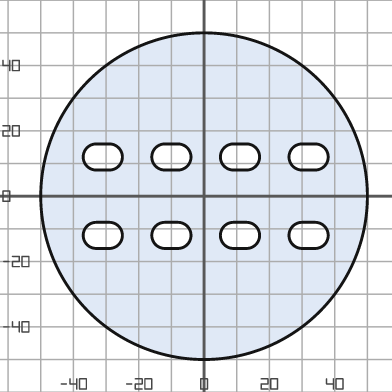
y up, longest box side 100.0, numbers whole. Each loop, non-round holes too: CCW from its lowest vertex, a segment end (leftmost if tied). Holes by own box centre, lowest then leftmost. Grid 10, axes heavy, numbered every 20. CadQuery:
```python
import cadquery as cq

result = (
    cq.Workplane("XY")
    .moveTo(0.0, 0.0)
    .circle(50.0)
    .moveTo(-33.0, -16.0)
    .lineTo(-29.0, -16.0)
    .threePointArc((-25.0, -12.0), (-29.0, -8.0))
    .lineTo(-33.0, -8.0)
    .threePointArc((-37.0, -12.0), (-33.0, -16.0))
    .close()
    .moveTo(-12.0, -16.0)
    .lineTo(-8.0, -16.0)
    .threePointArc((-4.0, -12.0), (-8.0, -8.0))
    .lineTo(-12.0, -8.0)
    .threePointArc((-16.0, -12.0), (-12.0, -16.0))
    .close()
    .moveTo(9.0, -16.0)
    .lineTo(13.0, -16.0)
    .threePointArc((17.0, -12.0), (13.0, -8.0))
    .lineTo(9.0, -8.0)
    .threePointArc((5.0, -12.0), (9.0, -16.0))
    .close()
    .moveTo(30.0, -16.0)
    .lineTo(34.0, -16.0)
    .threePointArc((38.0, -12.0), (34.0, -8.0))
    .lineTo(30.0, -8.0)
    .threePointArc((26.0, -12.0), (30.0, -16.0))
    .close()
    .moveTo(-33.0, 8.0)
    .lineTo(-29.0, 8.0)
    .threePointArc((-25.0, 12.0), (-29.0, 16.0))
    .lineTo(-33.0, 16.0)
    .threePointArc((-37.0, 12.0), (-33.0, 8.0))
    .close()
    .moveTo(-12.0, 8.0)
    .lineTo(-8.0, 8.0)
    .threePointArc((-4.0, 12.0), (-8.0, 16.0))
    .lineTo(-12.0, 16.0)
    .threePointArc((-16.0, 12.0), (-12.0, 8.0))
    .close()
    .moveTo(9.0, 8.0)
    .lineTo(13.0, 8.0)
    .threePointArc((17.0, 12.0), (13.0, 16.0))
    .lineTo(9.0, 16.0)
    .threePointArc((5.0, 12.0), (9.0, 8.0))
    .close()
    .moveTo(30.0, 8.0)
    .lineTo(34.0, 8.0)
    .threePointArc((38.0, 12.0), (34.0, 16.0))
    .lineTo(30.0, 16.0)
    .threePointArc((26.0, 12.0), (30.0, 8.0))
    .close()
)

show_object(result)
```